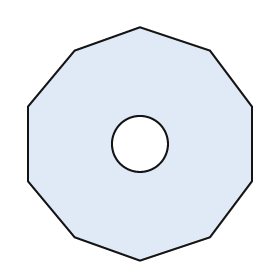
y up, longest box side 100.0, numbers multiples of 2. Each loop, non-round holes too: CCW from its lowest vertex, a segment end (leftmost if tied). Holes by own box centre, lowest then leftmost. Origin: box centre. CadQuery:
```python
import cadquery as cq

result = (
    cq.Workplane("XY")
    .moveTo(0.0, -50.0)
    .lineTo(30.0, -40.0)
    .lineTo(48.0, -16.0)
    .lineTo(48.0, 16.0)
    .lineTo(30.0, 40.0)
    .lineTo(0.0, 50.0)
    .lineTo(-28.0, 40.0)
    .lineTo(-48.0, 16.0)
    .lineTo(-48.0, -16.0)
    .lineTo(-28.0, -40.0)
    .close()
    .moveTo(0.0, 0.0)
    .circle(12.0)
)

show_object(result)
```